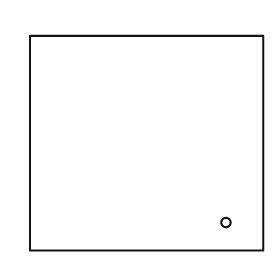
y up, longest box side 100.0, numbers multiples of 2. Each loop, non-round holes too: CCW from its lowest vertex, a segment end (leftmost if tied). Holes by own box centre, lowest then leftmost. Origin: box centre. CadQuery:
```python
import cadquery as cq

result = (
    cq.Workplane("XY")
    .moveTo(-50.0, -46.0)
    .lineTo(50.0, -46.0)
    .lineTo(50.0, 46.0)
    .lineTo(-50.0, 46.0)
    .close()
    .moveTo(34.0, -34.0)
    .circle(2.0)
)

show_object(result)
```